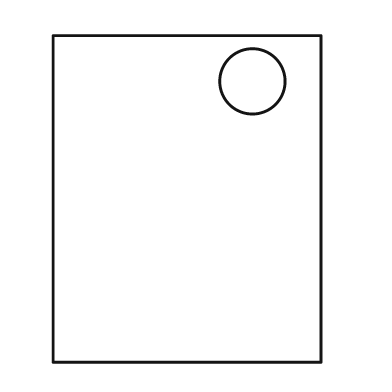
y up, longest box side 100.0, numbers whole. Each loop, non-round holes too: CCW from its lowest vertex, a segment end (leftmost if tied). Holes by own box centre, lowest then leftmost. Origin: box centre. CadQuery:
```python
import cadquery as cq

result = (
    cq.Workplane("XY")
    .moveTo(-41.0, -50.0)
    .lineTo(41.0, -50.0)
    .lineTo(41.0, 50.0)
    .lineTo(-41.0, 50.0)
    .close()
    .moveTo(20.0, 36.0)
    .circle(10.0)
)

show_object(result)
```